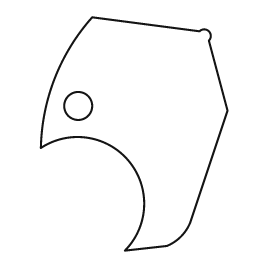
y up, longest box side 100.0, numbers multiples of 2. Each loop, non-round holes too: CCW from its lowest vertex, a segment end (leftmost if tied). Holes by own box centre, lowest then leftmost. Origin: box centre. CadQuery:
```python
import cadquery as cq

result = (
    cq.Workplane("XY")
    .moveTo(-4.0, -50.0)
    .lineTo(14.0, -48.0)
    .threePointArc((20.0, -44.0), (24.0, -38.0))
    .lineTo(40.0, 10.0)
    .lineTo(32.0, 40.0)
    .threePointArc((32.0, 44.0), (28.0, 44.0))
    .lineTo(-18.0, 50.0)
    .threePointArc((-34.0, 24.0), (-40.0, -6.0))
    .threePointArc((-2.0, -12.0), (-4.0, -50.0))
    .close()
    .moveTo(-24.0, 12.0)
    .circle(6.0)
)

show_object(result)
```